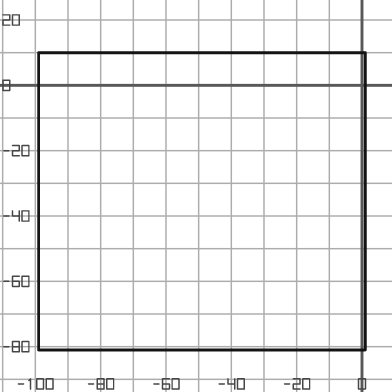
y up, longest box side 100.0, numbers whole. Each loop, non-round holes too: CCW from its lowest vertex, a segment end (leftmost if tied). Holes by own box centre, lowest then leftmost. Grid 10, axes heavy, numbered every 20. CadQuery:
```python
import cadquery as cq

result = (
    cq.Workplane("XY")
    .moveTo(-99.0, -81.0)
    .lineTo(1.0, -81.0)
    .lineTo(1.0, 10.0)
    .lineTo(-99.0, 10.0)
    .close()
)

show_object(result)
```